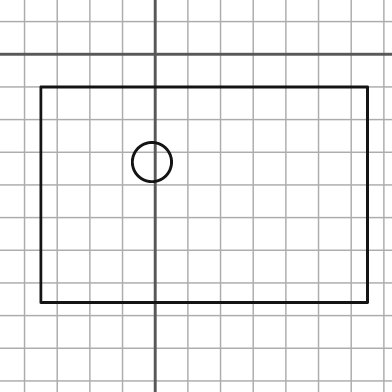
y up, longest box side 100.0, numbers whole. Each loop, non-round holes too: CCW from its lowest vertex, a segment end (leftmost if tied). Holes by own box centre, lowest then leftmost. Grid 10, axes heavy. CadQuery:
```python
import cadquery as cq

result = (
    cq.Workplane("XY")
    .moveTo(-35.0, -76.0)
    .lineTo(65.0, -76.0)
    .lineTo(65.0, -10.0)
    .lineTo(-35.0, -10.0)
    .close()
    .moveTo(-1.0, -33.0)
    .circle(6.0)
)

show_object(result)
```